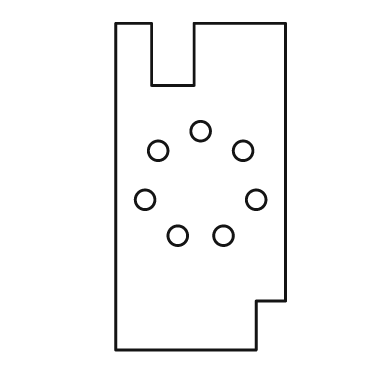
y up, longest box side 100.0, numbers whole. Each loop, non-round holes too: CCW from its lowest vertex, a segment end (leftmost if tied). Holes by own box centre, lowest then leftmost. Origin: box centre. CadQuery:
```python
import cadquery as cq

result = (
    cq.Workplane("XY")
    .moveTo(-26.0, -50.0)
    .lineTo(17.0, -50.0)
    .lineTo(17.0, -35.0)
    .lineTo(26.0, -35.0)
    .lineTo(26.0, 50.0)
    .lineTo(-2.0, 50.0)
    .lineTo(-2.0, 31.0)
    .lineTo(-15.0, 31.0)
    .lineTo(-15.0, 50.0)
    .lineTo(-26.0, 50.0)
    .close()
    .moveTo(-7.0, -15.0)
    .circle(3.0)
    .moveTo(7.0, -15.0)
    .circle(3.0)
    .moveTo(-17.0, -4.0)
    .circle(3.0)
    .moveTo(17.0, -4.0)
    .circle(3.0)
    .moveTo(-13.0, 11.0)
    .circle(3.0)
    .moveTo(13.0, 11.0)
    .circle(3.0)
    .moveTo(0.0, 17.0)
    .circle(3.0)
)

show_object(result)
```